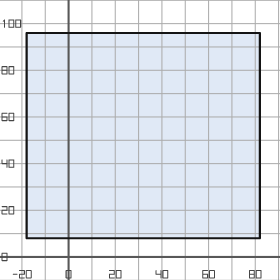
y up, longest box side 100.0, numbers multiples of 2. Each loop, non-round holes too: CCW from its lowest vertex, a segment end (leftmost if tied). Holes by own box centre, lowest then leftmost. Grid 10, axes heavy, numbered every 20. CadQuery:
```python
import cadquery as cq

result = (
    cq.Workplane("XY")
    .moveTo(-18.0, 8.0)
    .lineTo(82.0, 8.0)
    .lineTo(82.0, 96.0)
    .lineTo(-18.0, 96.0)
    .close()
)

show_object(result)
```